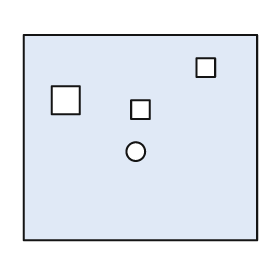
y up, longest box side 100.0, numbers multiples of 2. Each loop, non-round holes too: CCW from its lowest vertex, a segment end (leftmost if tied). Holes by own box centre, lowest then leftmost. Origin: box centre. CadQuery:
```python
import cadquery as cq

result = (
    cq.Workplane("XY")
    .moveTo(-50.0, -44.0)
    .lineTo(50.0, -44.0)
    .lineTo(50.0, 44.0)
    .lineTo(-50.0, 44.0)
    .close()
    .moveTo(-2.0, -6.0)
    .circle(4.0)
    .moveTo(-4.0, 8.0)
    .lineTo(4.0, 8.0)
    .lineTo(4.0, 16.0)
    .lineTo(-4.0, 16.0)
    .close()
    .moveTo(-38.0, 10.0)
    .lineTo(-26.0, 10.0)
    .lineTo(-26.0, 22.0)
    .lineTo(-38.0, 22.0)
    .close()
    .moveTo(24.0, 26.0)
    .lineTo(32.0, 26.0)
    .lineTo(32.0, 34.0)
    .lineTo(24.0, 34.0)
    .close()
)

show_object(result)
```